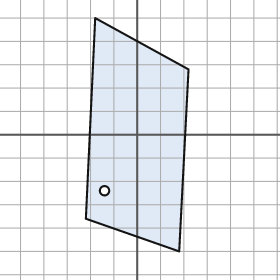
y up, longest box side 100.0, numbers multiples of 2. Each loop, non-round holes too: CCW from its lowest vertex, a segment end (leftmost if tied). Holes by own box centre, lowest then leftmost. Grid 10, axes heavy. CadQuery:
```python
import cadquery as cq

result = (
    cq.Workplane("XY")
    .moveTo(18.0, -50.0)
    .lineTo(22.0, 28.0)
    .lineTo(-18.0, 50.0)
    .lineTo(-22.0, -36.0)
    .close()
    .moveTo(-14.0, -24.0)
    .circle(2.0)
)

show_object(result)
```